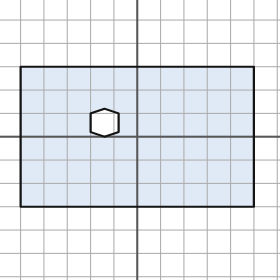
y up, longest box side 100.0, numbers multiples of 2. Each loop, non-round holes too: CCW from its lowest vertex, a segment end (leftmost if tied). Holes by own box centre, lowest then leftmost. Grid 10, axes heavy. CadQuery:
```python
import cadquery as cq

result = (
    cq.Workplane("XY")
    .moveTo(-50.0, -30.0)
    .lineTo(50.0, -30.0)
    .lineTo(50.0, 30.0)
    .lineTo(-50.0, 30.0)
    .close()
    .moveTo(-14.0, 0.0)
    .lineTo(-8.0, 2.0)
    .lineTo(-8.0, 10.0)
    .lineTo(-14.0, 12.0)
    .lineTo(-20.0, 10.0)
    .lineTo(-20.0, 2.0)
    .close()
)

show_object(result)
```